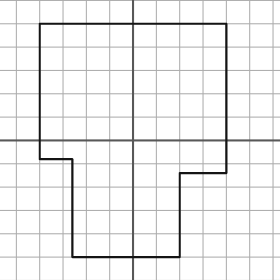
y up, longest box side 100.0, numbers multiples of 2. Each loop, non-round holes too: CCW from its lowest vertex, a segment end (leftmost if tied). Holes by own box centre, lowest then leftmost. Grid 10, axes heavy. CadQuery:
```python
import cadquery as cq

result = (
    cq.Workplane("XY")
    .moveTo(-26.0, -50.0)
    .lineTo(20.0, -50.0)
    .lineTo(20.0, -14.0)
    .lineTo(40.0, -14.0)
    .lineTo(40.0, 50.0)
    .lineTo(-40.0, 50.0)
    .lineTo(-40.0, -8.0)
    .lineTo(-26.0, -8.0)
    .close()
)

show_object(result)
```